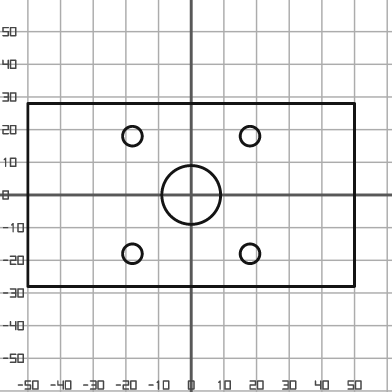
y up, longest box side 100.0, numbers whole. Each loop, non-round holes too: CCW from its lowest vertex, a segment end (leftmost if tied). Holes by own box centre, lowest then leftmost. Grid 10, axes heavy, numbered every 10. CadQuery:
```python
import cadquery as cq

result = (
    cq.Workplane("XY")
    .moveTo(-50.0, -28.0)
    .lineTo(50.0, -28.0)
    .lineTo(50.0, 28.0)
    .lineTo(-50.0, 28.0)
    .close()
    .moveTo(-18.0, -18.0)
    .circle(3.0)
    .moveTo(18.0, -18.0)
    .circle(3.0)
    .moveTo(0.0, 0.0)
    .circle(9.0)
    .moveTo(-18.0, 18.0)
    .circle(3.0)
    .moveTo(18.0, 18.0)
    .circle(3.0)
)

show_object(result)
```